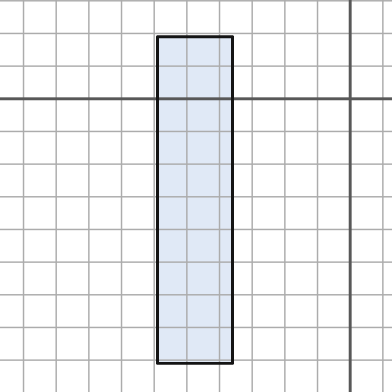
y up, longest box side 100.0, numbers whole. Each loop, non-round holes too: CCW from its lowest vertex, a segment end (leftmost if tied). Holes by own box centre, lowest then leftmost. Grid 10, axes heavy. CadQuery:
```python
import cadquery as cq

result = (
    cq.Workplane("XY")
    .moveTo(-59.0, -81.0)
    .lineTo(-36.0, -81.0)
    .lineTo(-36.0, 19.0)
    .lineTo(-59.0, 19.0)
    .close()
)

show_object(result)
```